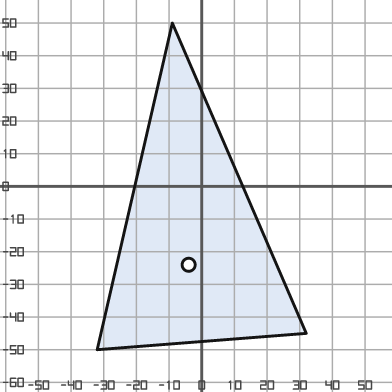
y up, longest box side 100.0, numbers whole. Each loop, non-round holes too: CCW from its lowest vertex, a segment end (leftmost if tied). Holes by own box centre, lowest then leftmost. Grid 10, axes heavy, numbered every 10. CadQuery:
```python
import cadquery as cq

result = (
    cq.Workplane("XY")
    .moveTo(-32.0, -50.0)
    .lineTo(32.0, -45.0)
    .lineTo(-9.0, 50.0)
    .close()
    .moveTo(-4.0, -24.0)
    .circle(2.0)
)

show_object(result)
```